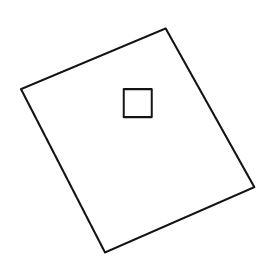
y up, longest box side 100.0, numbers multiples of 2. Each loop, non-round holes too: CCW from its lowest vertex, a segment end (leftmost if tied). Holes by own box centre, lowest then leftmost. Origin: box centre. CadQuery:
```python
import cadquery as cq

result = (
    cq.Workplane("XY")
    .moveTo(-14.0, -48.0)
    .lineTo(50.0, -20.0)
    .lineTo(12.0, 48.0)
    .lineTo(-50.0, 22.0)
    .close()
    .moveTo(-6.0, 10.0)
    .lineTo(6.0, 10.0)
    .lineTo(6.0, 22.0)
    .lineTo(-6.0, 22.0)
    .close()
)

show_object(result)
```